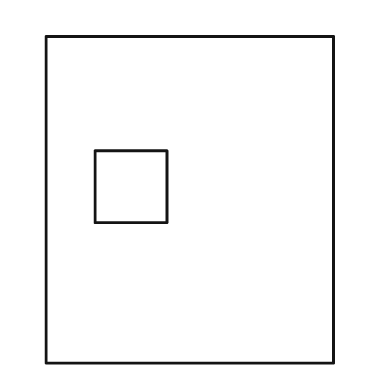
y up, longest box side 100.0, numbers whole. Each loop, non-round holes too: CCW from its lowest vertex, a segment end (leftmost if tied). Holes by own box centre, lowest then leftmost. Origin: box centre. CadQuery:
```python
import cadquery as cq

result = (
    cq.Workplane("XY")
    .moveTo(-44.0, -50.0)
    .lineTo(44.0, -50.0)
    .lineTo(44.0, 50.0)
    .lineTo(-44.0, 50.0)
    .close()
    .moveTo(-29.0, -7.0)
    .lineTo(-7.0, -7.0)
    .lineTo(-7.0, 15.0)
    .lineTo(-29.0, 15.0)
    .close()
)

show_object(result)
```